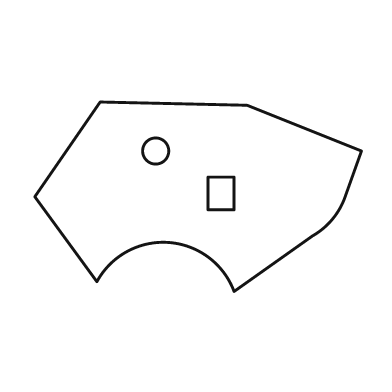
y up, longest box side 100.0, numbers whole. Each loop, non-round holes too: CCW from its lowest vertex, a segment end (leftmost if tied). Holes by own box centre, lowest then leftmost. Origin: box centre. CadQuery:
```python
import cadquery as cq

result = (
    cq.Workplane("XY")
    .moveTo(11.0, -29.0)
    .lineTo(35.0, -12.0)
    .threePointArc((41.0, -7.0), (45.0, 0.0))
    .lineTo(50.0, 14.0)
    .lineTo(15.0, 28.0)
    .lineTo(-30.0, 29.0)
    .lineTo(-50.0, 0.0)
    .lineTo(-31.0, -26.0)
    .threePointArc((-9.0, -14.0), (11.0, -29.0))
    .close()
    .moveTo(3.0, -4.0)
    .lineTo(11.0, -4.0)
    .lineTo(11.0, 6.0)
    .lineTo(3.0, 6.0)
    .close()
    .moveTo(-13.0, 14.0)
    .circle(4.0)
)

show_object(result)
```